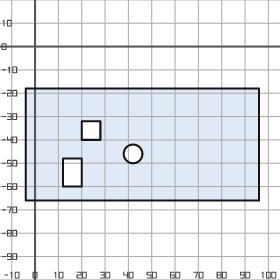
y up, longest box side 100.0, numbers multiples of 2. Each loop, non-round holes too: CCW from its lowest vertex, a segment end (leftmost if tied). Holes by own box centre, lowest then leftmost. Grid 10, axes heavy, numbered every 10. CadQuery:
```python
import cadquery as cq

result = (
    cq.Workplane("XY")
    .moveTo(-4.0, -66.0)
    .lineTo(96.0, -66.0)
    .lineTo(96.0, -18.0)
    .lineTo(-4.0, -18.0)
    .close()
    .moveTo(12.0, -60.0)
    .lineTo(20.0, -60.0)
    .lineTo(20.0, -48.0)
    .lineTo(12.0, -48.0)
    .close()
    .moveTo(42.0, -46.0)
    .circle(4.0)
    .moveTo(20.0, -40.0)
    .lineTo(28.0, -40.0)
    .lineTo(28.0, -32.0)
    .lineTo(20.0, -32.0)
    .close()
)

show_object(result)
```